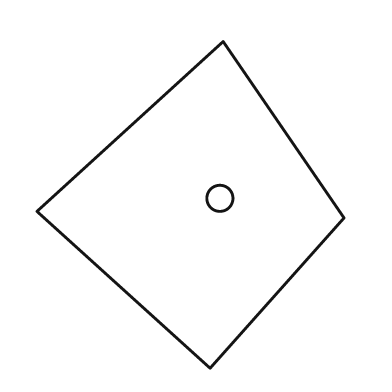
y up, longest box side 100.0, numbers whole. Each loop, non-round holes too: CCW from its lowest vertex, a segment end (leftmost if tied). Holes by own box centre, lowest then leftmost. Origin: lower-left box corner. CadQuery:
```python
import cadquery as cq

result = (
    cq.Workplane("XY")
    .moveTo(53.0, 0.0)
    .lineTo(94.0, 46.0)
    .lineTo(57.0, 100.0)
    .lineTo(0.0, 48.0)
    .close()
    .moveTo(56.0, 52.0)
    .circle(4.0)
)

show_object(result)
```